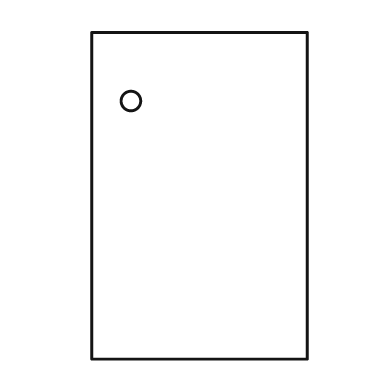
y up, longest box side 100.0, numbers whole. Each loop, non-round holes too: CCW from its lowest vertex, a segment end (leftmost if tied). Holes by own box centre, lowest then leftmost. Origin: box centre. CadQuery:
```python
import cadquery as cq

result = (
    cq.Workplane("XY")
    .moveTo(-33.0, -50.0)
    .lineTo(33.0, -50.0)
    .lineTo(33.0, 50.0)
    .lineTo(-33.0, 50.0)
    .close()
    .moveTo(-21.0, 29.0)
    .circle(3.0)
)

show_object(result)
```